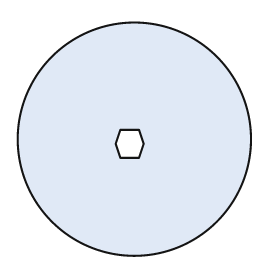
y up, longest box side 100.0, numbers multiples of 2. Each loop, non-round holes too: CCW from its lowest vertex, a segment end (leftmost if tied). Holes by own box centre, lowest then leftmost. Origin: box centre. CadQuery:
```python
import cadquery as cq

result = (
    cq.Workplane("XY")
    .moveTo(0.0, 0.0)
    .circle(50.0)
    .moveTo(-6.0, -8.0)
    .lineTo(2.0, -8.0)
    .lineTo(4.0, -2.0)
    .lineTo(2.0, 4.0)
    .lineTo(-6.0, 4.0)
    .lineTo(-8.0, -2.0)
    .close()
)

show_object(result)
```